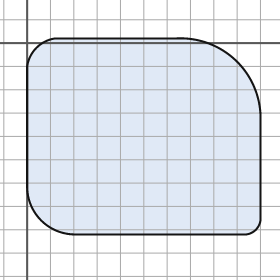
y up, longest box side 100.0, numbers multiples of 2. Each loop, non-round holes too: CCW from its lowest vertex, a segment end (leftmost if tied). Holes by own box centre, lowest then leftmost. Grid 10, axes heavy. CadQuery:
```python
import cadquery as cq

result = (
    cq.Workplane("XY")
    .moveTo(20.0, -82.0)
    .lineTo(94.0, -82.0)
    .threePointArc((98.0, -80.0), (100.0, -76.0))
    .lineTo(100.0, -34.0)
    .threePointArc((90.0, -8.0), (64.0, 2.0))
    .lineTo(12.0, 2.0)
    .threePointArc((4.0, -2.0), (0.0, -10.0))
    .lineTo(0.0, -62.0)
    .threePointArc((6.0, -76.0), (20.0, -82.0))
    .close()
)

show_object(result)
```